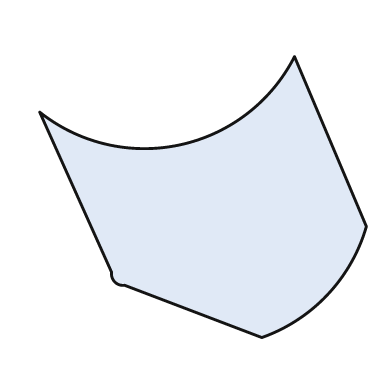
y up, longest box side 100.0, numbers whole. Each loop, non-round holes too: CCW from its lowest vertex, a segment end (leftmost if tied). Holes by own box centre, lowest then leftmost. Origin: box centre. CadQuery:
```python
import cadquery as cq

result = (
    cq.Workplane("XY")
    .moveTo(18.0, -43.0)
    .threePointArc((38.0, -30.0), (50.0, -9.0))
    .lineTo(28.0, 43.0)
    .threePointArc((-7.0, 16.0), (-50.0, 26.0))
    .lineTo(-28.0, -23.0)
    .threePointArc((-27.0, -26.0), (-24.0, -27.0))
    .close()
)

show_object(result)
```